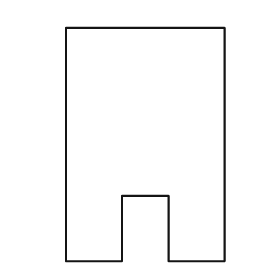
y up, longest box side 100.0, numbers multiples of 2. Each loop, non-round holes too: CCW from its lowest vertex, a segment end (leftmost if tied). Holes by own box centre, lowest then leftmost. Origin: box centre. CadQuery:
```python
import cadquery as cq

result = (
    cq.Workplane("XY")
    .moveTo(-34.0, -50.0)
    .lineTo(-10.0, -50.0)
    .lineTo(-10.0, -22.0)
    .lineTo(10.0, -22.0)
    .lineTo(10.0, -50.0)
    .lineTo(34.0, -50.0)
    .lineTo(34.0, 50.0)
    .lineTo(-34.0, 50.0)
    .close()
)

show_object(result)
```